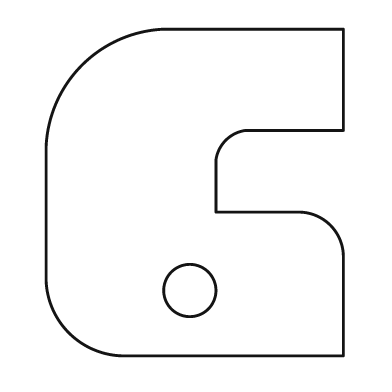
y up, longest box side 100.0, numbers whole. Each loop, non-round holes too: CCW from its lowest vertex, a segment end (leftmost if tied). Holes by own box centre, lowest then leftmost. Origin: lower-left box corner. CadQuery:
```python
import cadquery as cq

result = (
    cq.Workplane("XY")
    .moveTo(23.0, 0.0)
    .lineTo(91.0, 0.0)
    .lineTo(91.0, 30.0)
    .threePointArc((87.0, 40.0), (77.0, 44.0))
    .lineTo(52.0, 44.0)
    .lineTo(52.0, 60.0)
    .threePointArc((55.0, 66.0), (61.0, 69.0))
    .lineTo(91.0, 69.0)
    .lineTo(91.0, 100.0)
    .lineTo(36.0, 100.0)
    .threePointArc((11.0, 89.0), (0.0, 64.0))
    .lineTo(0.0, 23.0)
    .threePointArc((7.0, 7.0), (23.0, 0.0))
    .close()
    .moveTo(44.0, 20.0)
    .circle(8.0)
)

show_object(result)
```